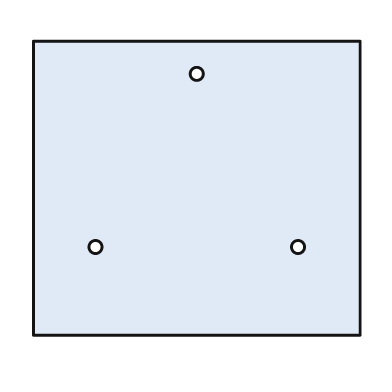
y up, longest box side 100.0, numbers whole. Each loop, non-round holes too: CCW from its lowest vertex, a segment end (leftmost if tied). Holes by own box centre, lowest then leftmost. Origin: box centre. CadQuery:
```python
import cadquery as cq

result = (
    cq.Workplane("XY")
    .moveTo(-50.0, -45.0)
    .lineTo(50.0, -45.0)
    .lineTo(50.0, 45.0)
    .lineTo(-50.0, 45.0)
    .close()
    .moveTo(-31.0, -18.0)
    .circle(2.0)
    .moveTo(31.0, -18.0)
    .circle(2.0)
    .moveTo(0.0, 35.0)
    .circle(2.0)
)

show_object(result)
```